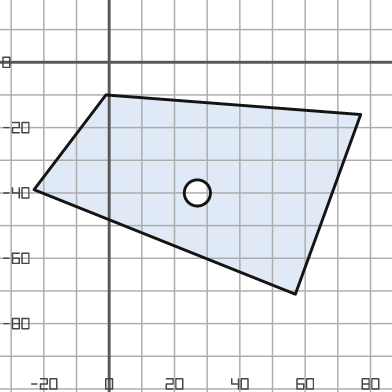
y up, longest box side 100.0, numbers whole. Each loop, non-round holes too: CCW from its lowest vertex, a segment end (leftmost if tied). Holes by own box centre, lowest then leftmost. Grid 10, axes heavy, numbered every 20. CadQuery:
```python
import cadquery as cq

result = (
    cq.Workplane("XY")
    .moveTo(57.0, -71.0)
    .lineTo(77.0, -16.0)
    .lineTo(-1.0, -10.0)
    .lineTo(-23.0, -39.0)
    .close()
    .moveTo(27.0, -40.0)
    .circle(4.0)
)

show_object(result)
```